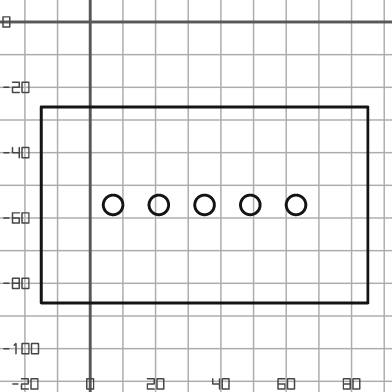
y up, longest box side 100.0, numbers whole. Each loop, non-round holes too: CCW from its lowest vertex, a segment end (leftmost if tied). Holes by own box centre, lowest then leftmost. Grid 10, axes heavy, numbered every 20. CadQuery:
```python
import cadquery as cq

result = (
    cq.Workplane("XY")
    .moveTo(-15.0, -86.0)
    .lineTo(85.0, -86.0)
    .lineTo(85.0, -26.0)
    .lineTo(-15.0, -26.0)
    .close()
    .moveTo(7.0, -56.0)
    .circle(3.0)
    .moveTo(21.0, -56.0)
    .circle(3.0)
    .moveTo(35.0, -56.0)
    .circle(3.0)
    .moveTo(49.0, -56.0)
    .circle(3.0)
    .moveTo(63.0, -56.0)
    .circle(3.0)
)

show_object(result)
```